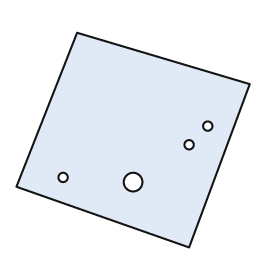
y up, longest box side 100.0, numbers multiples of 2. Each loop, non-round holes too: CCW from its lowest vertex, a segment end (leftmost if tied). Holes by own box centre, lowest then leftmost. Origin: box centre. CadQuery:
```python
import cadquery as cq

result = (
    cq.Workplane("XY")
    .moveTo(24.0, -46.0)
    .lineTo(50.0, 24.0)
    .lineTo(-24.0, 46.0)
    .lineTo(-50.0, -20.0)
    .close()
    .moveTo(0.0, -18.0)
    .circle(4.0)
    .moveTo(-30.0, -16.0)
    .circle(2.0)
    .moveTo(24.0, -2.0)
    .circle(2.0)
    .moveTo(32.0, 6.0)
    .circle(2.0)
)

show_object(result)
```